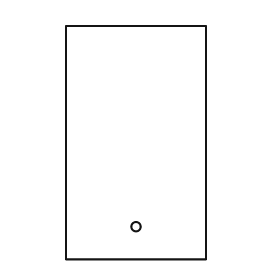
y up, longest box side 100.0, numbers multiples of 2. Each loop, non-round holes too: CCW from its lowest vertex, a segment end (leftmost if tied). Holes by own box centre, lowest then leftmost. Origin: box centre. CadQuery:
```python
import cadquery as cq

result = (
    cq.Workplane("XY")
    .moveTo(-30.0, -50.0)
    .lineTo(30.0, -50.0)
    .lineTo(30.0, 50.0)
    .lineTo(-30.0, 50.0)
    .close()
    .moveTo(0.0, -36.0)
    .circle(2.0)
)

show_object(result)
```